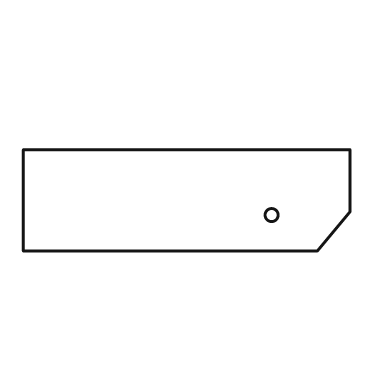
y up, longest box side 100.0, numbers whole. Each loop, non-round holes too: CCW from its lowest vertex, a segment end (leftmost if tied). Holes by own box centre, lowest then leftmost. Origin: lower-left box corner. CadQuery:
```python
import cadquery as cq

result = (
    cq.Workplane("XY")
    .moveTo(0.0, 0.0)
    .lineTo(90.0, 0.0)
    .lineTo(100.0, 12.0)
    .lineTo(100.0, 31.0)
    .lineTo(0.0, 31.0)
    .close()
    .moveTo(76.0, 11.0)
    .circle(2.0)
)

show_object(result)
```